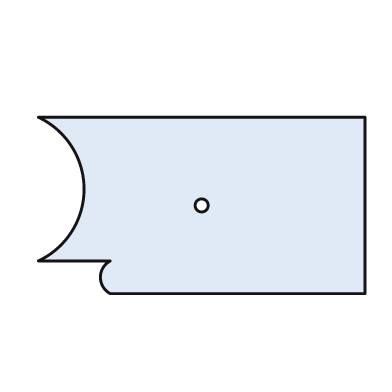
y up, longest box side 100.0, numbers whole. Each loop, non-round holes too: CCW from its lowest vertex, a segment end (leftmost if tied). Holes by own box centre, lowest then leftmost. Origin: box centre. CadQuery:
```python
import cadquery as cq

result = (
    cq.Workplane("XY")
    .moveTo(-28.0, -27.0)
    .lineTo(50.0, -27.0)
    .lineTo(50.0, 27.0)
    .lineTo(-50.0, 27.0)
    .threePointArc((-36.0, 5.0), (-50.0, -17.0))
    .lineTo(-28.0, -17.0)
    .threePointArc((-31.0, -22.0), (-28.0, -27.0))
    .close()
    .moveTo(0.0, 0.0)
    .circle(2.0)
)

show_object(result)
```